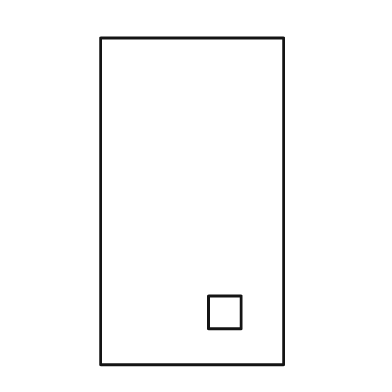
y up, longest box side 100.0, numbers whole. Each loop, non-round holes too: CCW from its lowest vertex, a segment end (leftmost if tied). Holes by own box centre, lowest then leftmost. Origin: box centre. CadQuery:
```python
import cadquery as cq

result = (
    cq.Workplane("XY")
    .moveTo(-28.0, -50.0)
    .lineTo(28.0, -50.0)
    .lineTo(28.0, 50.0)
    .lineTo(-28.0, 50.0)
    .close()
    .moveTo(5.0, -39.0)
    .lineTo(15.0, -39.0)
    .lineTo(15.0, -29.0)
    .lineTo(5.0, -29.0)
    .close()
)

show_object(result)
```